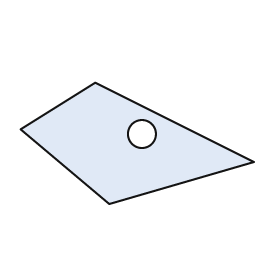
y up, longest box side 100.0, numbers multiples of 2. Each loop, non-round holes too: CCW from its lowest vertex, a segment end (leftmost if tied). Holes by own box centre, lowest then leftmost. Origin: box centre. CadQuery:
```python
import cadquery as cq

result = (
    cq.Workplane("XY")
    .moveTo(-12.0, -26.0)
    .lineTo(50.0, -8.0)
    .lineTo(-18.0, 26.0)
    .lineTo(-50.0, 6.0)
    .close()
    .moveTo(2.0, 4.0)
    .circle(6.0)
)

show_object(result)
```